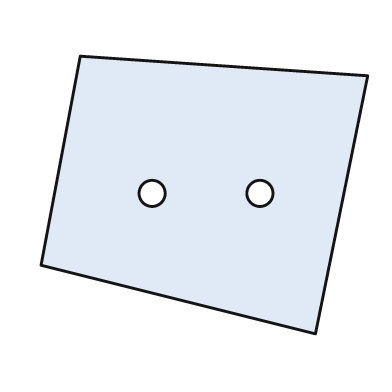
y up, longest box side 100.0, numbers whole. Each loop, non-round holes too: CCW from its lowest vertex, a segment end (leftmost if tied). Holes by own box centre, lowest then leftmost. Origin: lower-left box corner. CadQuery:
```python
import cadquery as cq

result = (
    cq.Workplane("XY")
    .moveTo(84.0, 0.0)
    .lineTo(100.0, 79.0)
    .lineTo(12.0, 85.0)
    .lineTo(0.0, 21.0)
    .close()
    .moveTo(34.0, 43.0)
    .circle(4.0)
    .moveTo(67.0, 43.0)
    .circle(4.0)
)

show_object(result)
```